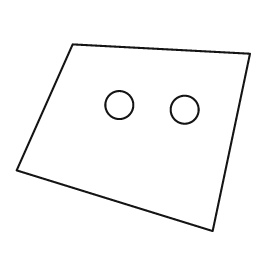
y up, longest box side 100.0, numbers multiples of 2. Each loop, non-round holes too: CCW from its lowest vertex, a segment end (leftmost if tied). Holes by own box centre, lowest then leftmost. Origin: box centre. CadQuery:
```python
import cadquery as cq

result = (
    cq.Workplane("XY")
    .moveTo(34.0, -40.0)
    .lineTo(50.0, 36.0)
    .lineTo(-26.0, 40.0)
    .lineTo(-50.0, -14.0)
    .close()
    .moveTo(22.0, 12.0)
    .circle(6.0)
    .moveTo(-6.0, 14.0)
    .circle(6.0)
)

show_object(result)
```